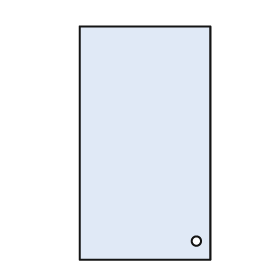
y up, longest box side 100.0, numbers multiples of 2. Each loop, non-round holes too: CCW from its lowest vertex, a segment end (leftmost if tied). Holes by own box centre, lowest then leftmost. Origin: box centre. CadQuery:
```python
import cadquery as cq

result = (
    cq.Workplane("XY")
    .moveTo(-28.0, -50.0)
    .lineTo(28.0, -50.0)
    .lineTo(28.0, 50.0)
    .lineTo(-28.0, 50.0)
    .close()
    .moveTo(22.0, -42.0)
    .circle(2.0)
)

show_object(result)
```